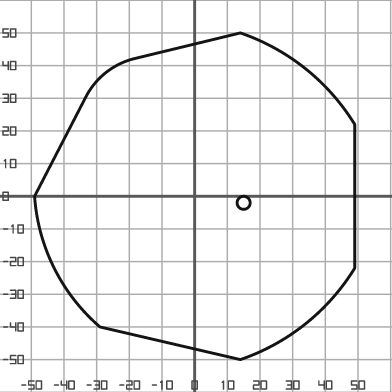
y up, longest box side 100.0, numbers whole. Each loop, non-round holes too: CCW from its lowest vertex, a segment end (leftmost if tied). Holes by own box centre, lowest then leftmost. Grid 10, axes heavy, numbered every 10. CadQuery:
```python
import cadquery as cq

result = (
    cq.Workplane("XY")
    .moveTo(14.0, -50.0)
    .threePointArc((34.0, -39.0), (49.0, -22.0))
    .lineTo(49.0, 22.0)
    .threePointArc((34.0, 39.0), (14.0, 50.0))
    .lineTo(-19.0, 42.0)
    .threePointArc((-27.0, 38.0), (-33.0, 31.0))
    .lineTo(-49.0, 0.0)
    .threePointArc((-43.0, -22.0), (-29.0, -40.0))
    .close()
    .moveTo(15.0, -2.0)
    .circle(2.0)
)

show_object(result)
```